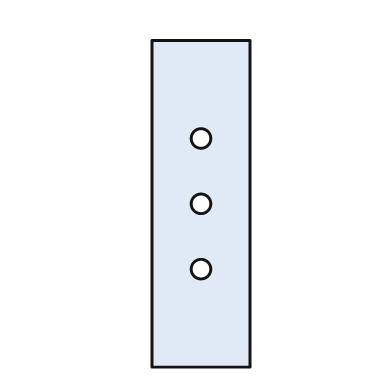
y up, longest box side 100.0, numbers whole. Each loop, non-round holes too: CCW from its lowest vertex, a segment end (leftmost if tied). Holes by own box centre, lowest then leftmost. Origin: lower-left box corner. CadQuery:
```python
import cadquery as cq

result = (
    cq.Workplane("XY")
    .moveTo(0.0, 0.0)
    .lineTo(30.0, 0.0)
    .lineTo(30.0, 100.0)
    .lineTo(0.0, 100.0)
    .close()
    .moveTo(15.0, 30.0)
    .circle(3.0)
    .moveTo(15.0, 50.0)
    .circle(3.0)
    .moveTo(15.0, 70.0)
    .circle(3.0)
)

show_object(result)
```